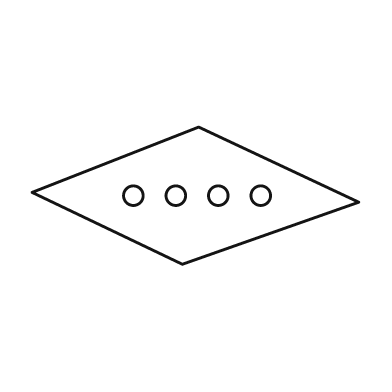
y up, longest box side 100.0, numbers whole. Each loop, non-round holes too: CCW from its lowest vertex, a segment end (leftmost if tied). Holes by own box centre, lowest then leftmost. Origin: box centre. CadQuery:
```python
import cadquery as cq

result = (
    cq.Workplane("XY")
    .moveTo(-4.0, -21.0)
    .lineTo(50.0, -2.0)
    .lineTo(1.0, 21.0)
    .lineTo(-50.0, 1.0)
    .close()
    .moveTo(-19.0, 0.0)
    .circle(3.0)
    .moveTo(-6.0, 0.0)
    .circle(3.0)
    .moveTo(7.0, 0.0)
    .circle(3.0)
    .moveTo(20.0, 0.0)
    .circle(3.0)
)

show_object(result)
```